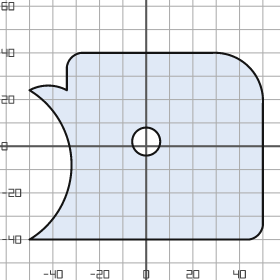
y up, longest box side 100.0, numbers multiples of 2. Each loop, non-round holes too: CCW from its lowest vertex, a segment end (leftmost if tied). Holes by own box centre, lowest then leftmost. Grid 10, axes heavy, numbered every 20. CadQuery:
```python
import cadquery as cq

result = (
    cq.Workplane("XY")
    .moveTo(-50.0, -40.0)
    .lineTo(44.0, -40.0)
    .threePointArc((48.0, -38.0), (50.0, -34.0))
    .lineTo(50.0, 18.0)
    .threePointArc((44.0, 34.0), (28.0, 40.0))
    .lineTo(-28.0, 40.0)
    .threePointArc((-32.0, 38.0), (-34.0, 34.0))
    .lineTo(-34.0, 24.0)
    .threePointArc((-42.0, 26.0), (-50.0, 24.0))
    .threePointArc((-32.0, -8.0), (-50.0, -40.0))
    .close()
    .moveTo(0.0, 2.0)
    .circle(6.0)
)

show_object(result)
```